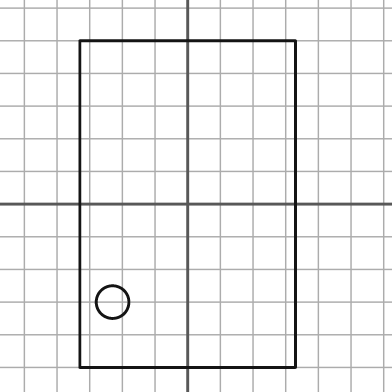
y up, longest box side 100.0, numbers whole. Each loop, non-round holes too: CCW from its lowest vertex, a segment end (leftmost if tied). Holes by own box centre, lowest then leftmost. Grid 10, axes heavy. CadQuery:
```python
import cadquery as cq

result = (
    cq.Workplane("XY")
    .moveTo(-33.0, -50.0)
    .lineTo(33.0, -50.0)
    .lineTo(33.0, 50.0)
    .lineTo(-33.0, 50.0)
    .close()
    .moveTo(-23.0, -30.0)
    .circle(5.0)
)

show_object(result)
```